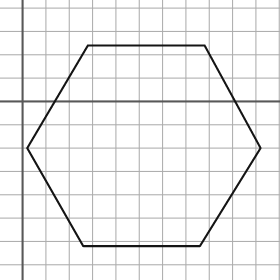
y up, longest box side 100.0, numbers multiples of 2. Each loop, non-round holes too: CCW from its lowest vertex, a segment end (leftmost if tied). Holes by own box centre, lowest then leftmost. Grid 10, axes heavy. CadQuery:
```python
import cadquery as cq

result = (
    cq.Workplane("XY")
    .moveTo(26.0, -62.0)
    .lineTo(76.0, -62.0)
    .lineTo(102.0, -20.0)
    .lineTo(78.0, 24.0)
    .lineTo(28.0, 24.0)
    .lineTo(2.0, -20.0)
    .close()
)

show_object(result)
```